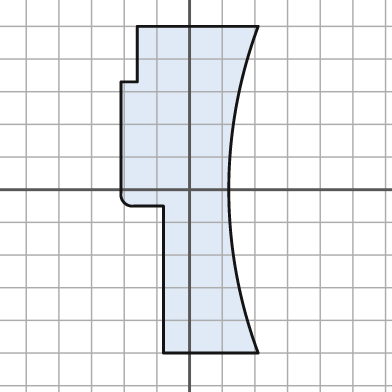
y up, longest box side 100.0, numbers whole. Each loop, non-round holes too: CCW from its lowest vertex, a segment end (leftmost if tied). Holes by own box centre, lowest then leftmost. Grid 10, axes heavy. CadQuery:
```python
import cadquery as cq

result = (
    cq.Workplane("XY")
    .moveTo(-8.0, -50.0)
    .lineTo(21.0, -50.0)
    .threePointArc((12.0, 0.0), (21.0, 50.0))
    .lineTo(-16.0, 50.0)
    .lineTo(-16.0, 33.0)
    .lineTo(-21.0, 33.0)
    .lineTo(-21.0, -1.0)
    .threePointArc((-20.0, -4.0), (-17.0, -5.0))
    .lineTo(-8.0, -5.0)
    .close()
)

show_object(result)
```